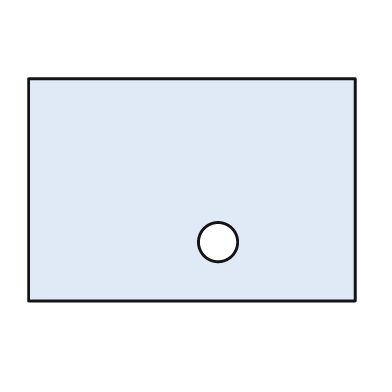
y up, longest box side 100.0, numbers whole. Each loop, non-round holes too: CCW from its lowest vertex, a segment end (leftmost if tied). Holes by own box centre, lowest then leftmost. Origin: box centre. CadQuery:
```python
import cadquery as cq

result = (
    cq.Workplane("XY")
    .moveTo(-50.0, -34.0)
    .lineTo(50.0, -34.0)
    .lineTo(50.0, 34.0)
    .lineTo(-50.0, 34.0)
    .close()
    .moveTo(8.0, -16.0)
    .circle(6.0)
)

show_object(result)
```